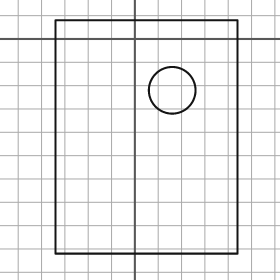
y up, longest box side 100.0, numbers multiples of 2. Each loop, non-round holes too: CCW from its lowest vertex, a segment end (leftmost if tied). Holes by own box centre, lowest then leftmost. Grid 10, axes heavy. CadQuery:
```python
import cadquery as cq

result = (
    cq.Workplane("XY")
    .moveTo(-34.0, -92.0)
    .lineTo(44.0, -92.0)
    .lineTo(44.0, 8.0)
    .lineTo(-34.0, 8.0)
    .close()
    .moveTo(16.0, -22.0)
    .circle(10.0)
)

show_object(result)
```